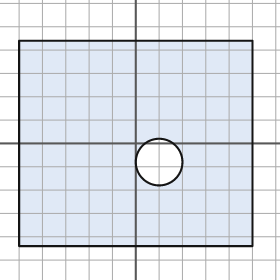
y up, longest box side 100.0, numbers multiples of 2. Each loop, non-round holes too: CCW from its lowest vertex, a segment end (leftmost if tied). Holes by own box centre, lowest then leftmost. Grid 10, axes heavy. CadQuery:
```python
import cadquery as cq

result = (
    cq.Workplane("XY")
    .moveTo(-50.0, -44.0)
    .lineTo(50.0, -44.0)
    .lineTo(50.0, 44.0)
    .lineTo(-50.0, 44.0)
    .close()
    .moveTo(10.0, -8.0)
    .circle(10.0)
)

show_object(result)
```